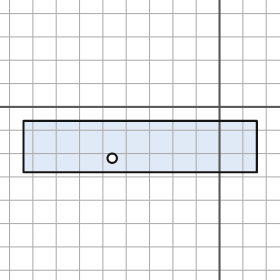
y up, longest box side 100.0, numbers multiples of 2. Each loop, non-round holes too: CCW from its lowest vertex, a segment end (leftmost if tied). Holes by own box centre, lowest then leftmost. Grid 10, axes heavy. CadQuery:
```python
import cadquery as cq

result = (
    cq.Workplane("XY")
    .moveTo(-84.0, -28.0)
    .lineTo(16.0, -28.0)
    .lineTo(16.0, -6.0)
    .lineTo(-84.0, -6.0)
    .close()
    .moveTo(-46.0, -22.0)
    .circle(2.0)
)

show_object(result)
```